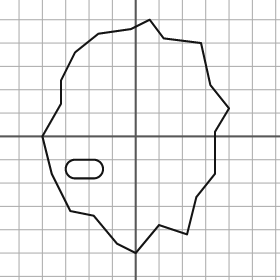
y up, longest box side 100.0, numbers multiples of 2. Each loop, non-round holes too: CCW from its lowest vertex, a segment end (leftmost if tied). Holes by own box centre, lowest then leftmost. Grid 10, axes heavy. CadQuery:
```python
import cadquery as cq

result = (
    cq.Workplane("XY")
    .moveTo(0.0, -50.0)
    .lineTo(10.0, -38.0)
    .lineTo(22.0, -42.0)
    .lineTo(26.0, -26.0)
    .lineTo(34.0, -16.0)
    .lineTo(34.0, 2.0)
    .lineTo(40.0, 12.0)
    .lineTo(32.0, 22.0)
    .lineTo(28.0, 40.0)
    .lineTo(12.0, 42.0)
    .lineTo(6.0, 50.0)
    .lineTo(-2.0, 46.0)
    .lineTo(-16.0, 44.0)
    .lineTo(-26.0, 36.0)
    .lineTo(-32.0, 24.0)
    .lineTo(-32.0, 14.0)
    .lineTo(-40.0, 0.0)
    .lineTo(-36.0, -16.0)
    .lineTo(-28.0, -32.0)
    .lineTo(-18.0, -34.0)
    .lineTo(-8.0, -46.0)
    .close()
    .moveTo(-26.0, -18.0)
    .lineTo(-18.0, -18.0)
    .threePointArc((-14.0, -14.0), (-18.0, -10.0))
    .lineTo(-26.0, -10.0)
    .threePointArc((-30.0, -14.0), (-26.0, -18.0))
    .close()
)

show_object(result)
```